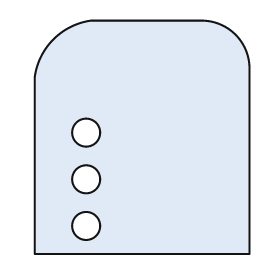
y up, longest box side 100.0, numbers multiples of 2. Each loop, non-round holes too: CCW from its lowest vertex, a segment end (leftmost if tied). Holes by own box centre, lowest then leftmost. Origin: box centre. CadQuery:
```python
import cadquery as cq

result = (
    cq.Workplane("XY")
    .moveTo(-46.0, -50.0)
    .lineTo(46.0, -50.0)
    .lineTo(46.0, 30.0)
    .threePointArc((40.0, 44.0), (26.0, 50.0))
    .lineTo(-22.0, 50.0)
    .threePointArc((-38.0, 42.0), (-46.0, 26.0))
    .close()
    .moveTo(-24.0, -38.0)
    .circle(6.0)
    .moveTo(-24.0, -18.0)
    .circle(6.0)
    .moveTo(-24.0, 2.0)
    .circle(6.0)
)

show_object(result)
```